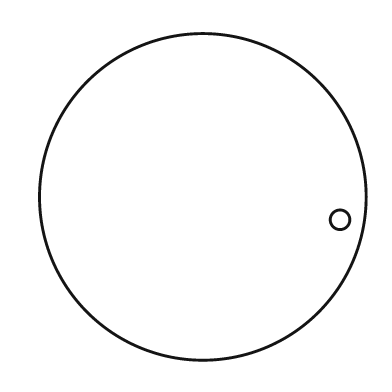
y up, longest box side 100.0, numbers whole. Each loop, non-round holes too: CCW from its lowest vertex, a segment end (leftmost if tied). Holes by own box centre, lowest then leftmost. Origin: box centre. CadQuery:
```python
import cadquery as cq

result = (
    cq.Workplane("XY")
    .moveTo(0.0, 0.0)
    .circle(50.0)
    .moveTo(42.0, -7.0)
    .circle(3.0)
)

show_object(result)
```